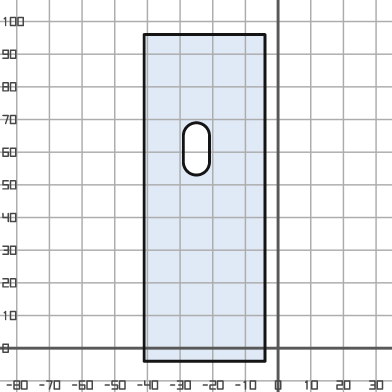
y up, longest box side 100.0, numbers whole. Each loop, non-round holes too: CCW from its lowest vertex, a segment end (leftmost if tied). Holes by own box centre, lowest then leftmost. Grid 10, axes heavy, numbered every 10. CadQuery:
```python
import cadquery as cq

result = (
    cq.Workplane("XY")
    .moveTo(-41.0, -4.0)
    .lineTo(-4.0, -4.0)
    .lineTo(-4.0, 96.0)
    .lineTo(-41.0, 96.0)
    .close()
    .moveTo(-29.0, 57.0)
    .threePointArc((-25.0, 53.0), (-21.0, 57.0))
    .lineTo(-21.0, 65.0)
    .threePointArc((-25.0, 69.0), (-29.0, 65.0))
    .close()
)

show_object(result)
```